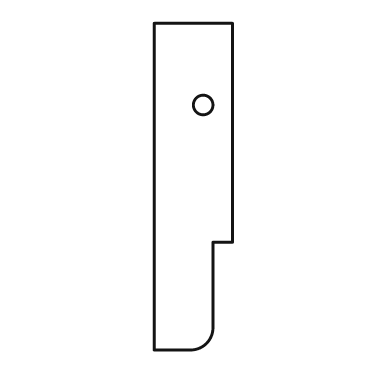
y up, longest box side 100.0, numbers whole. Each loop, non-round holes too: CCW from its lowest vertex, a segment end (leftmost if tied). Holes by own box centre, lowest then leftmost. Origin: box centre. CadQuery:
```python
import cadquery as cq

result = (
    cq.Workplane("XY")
    .moveTo(-12.0, -50.0)
    .lineTo(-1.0, -50.0)
    .threePointArc((4.0, -48.0), (6.0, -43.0))
    .lineTo(6.0, -17.0)
    .lineTo(12.0, -17.0)
    .lineTo(12.0, 50.0)
    .lineTo(-12.0, 50.0)
    .close()
    .moveTo(3.0, 25.0)
    .circle(3.0)
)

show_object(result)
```